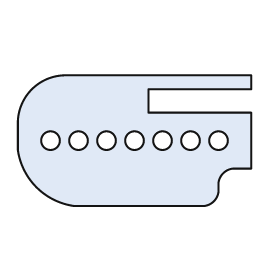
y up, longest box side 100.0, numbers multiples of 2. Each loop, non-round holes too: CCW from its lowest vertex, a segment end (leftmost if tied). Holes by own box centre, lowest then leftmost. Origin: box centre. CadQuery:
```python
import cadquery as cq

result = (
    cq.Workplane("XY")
    .moveTo(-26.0, -28.0)
    .lineTo(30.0, -28.0)
    .threePointArc((34.0, -26.0), (36.0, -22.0))
    .lineTo(36.0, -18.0)
    .threePointArc((38.0, -14.0), (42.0, -12.0))
    .lineTo(50.0, -12.0)
    .lineTo(50.0, 12.0)
    .lineTo(6.0, 12.0)
    .lineTo(6.0, 22.0)
    .lineTo(50.0, 22.0)
    .lineTo(50.0, 28.0)
    .lineTo(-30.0, 28.0)
    .threePointArc((-44.0, 22.0), (-50.0, 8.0))
    .lineTo(-50.0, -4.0)
    .threePointArc((-42.0, -20.0), (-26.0, -28.0))
    .close()
    .moveTo(-36.0, 0.0)
    .circle(4.0)
    .moveTo(-24.0, 0.0)
    .circle(4.0)
    .moveTo(-12.0, 0.0)
    .circle(4.0)
    .moveTo(0.0, 0.0)
    .circle(4.0)
    .moveTo(12.0, 0.0)
    .circle(4.0)
    .moveTo(24.0, 0.0)
    .circle(4.0)
    .moveTo(36.0, 0.0)
    .circle(4.0)
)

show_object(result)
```